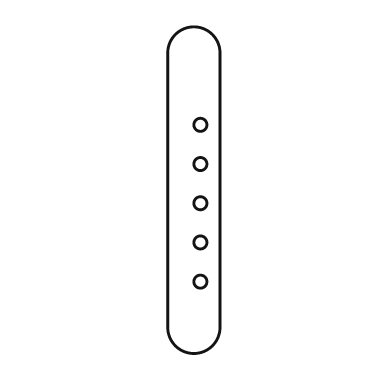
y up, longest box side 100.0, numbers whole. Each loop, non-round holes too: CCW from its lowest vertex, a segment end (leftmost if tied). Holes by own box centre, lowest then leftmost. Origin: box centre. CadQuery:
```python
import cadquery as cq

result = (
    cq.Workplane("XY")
    .moveTo(-8.0, -42.0)
    .threePointArc((0.0, -50.0), (8.0, -42.0))
    .lineTo(8.0, 42.0)
    .threePointArc((0.0, 50.0), (-8.0, 42.0))
    .close()
    .moveTo(2.0, -28.0)
    .circle(2.0)
    .moveTo(2.0, -16.0)
    .circle(2.0)
    .moveTo(2.0, -4.0)
    .circle(2.0)
    .moveTo(2.0, 8.0)
    .circle(2.0)
    .moveTo(2.0, 20.0)
    .circle(2.0)
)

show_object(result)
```